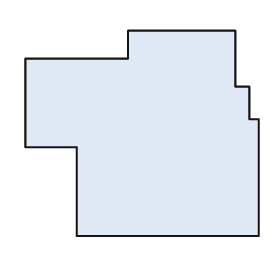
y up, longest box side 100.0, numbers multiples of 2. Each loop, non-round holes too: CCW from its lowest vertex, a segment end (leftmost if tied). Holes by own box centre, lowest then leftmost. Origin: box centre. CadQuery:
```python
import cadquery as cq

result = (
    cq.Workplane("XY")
    .moveTo(-28.0, -44.0)
    .lineTo(50.0, -44.0)
    .lineTo(50.0, 6.0)
    .lineTo(46.0, 6.0)
    .lineTo(46.0, 20.0)
    .lineTo(40.0, 20.0)
    .lineTo(40.0, 44.0)
    .lineTo(-6.0, 44.0)
    .lineTo(-6.0, 32.0)
    .lineTo(-50.0, 32.0)
    .lineTo(-50.0, -6.0)
    .lineTo(-28.0, -6.0)
    .close()
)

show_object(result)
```